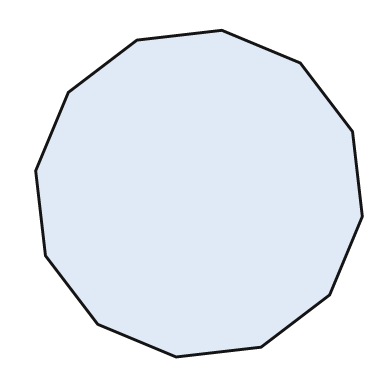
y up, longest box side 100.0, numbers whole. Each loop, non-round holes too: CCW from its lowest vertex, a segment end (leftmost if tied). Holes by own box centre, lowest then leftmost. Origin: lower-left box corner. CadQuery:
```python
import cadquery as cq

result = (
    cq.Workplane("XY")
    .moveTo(43.0, 0.0)
    .lineTo(69.0, 3.0)
    .lineTo(90.0, 19.0)
    .lineTo(100.0, 43.0)
    .lineTo(97.0, 69.0)
    .lineTo(81.0, 90.0)
    .lineTo(57.0, 100.0)
    .lineTo(31.0, 97.0)
    .lineTo(10.0, 81.0)
    .lineTo(0.0, 57.0)
    .lineTo(3.0, 31.0)
    .lineTo(19.0, 10.0)
    .close()
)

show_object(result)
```